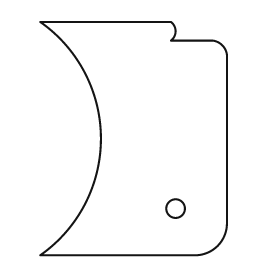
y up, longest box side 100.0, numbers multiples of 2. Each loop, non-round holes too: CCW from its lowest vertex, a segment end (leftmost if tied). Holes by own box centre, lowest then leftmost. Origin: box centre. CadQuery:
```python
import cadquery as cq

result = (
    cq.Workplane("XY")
    .moveTo(-40.0, -50.0)
    .lineTo(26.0, -50.0)
    .threePointArc((36.0, -46.0), (40.0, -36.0))
    .lineTo(40.0, 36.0)
    .threePointArc((38.0, 40.0), (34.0, 42.0))
    .lineTo(16.0, 42.0)
    .threePointArc((18.0, 46.0), (16.0, 50.0))
    .lineTo(-40.0, 50.0)
    .threePointArc((-14.0, 0.0), (-40.0, -50.0))
    .close()
    .moveTo(18.0, -30.0)
    .circle(4.0)
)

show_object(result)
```